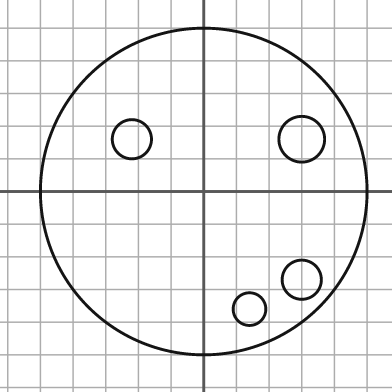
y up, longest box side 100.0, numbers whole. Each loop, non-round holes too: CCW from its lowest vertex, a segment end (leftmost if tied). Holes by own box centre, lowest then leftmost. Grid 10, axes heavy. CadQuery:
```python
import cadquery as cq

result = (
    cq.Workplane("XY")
    .moveTo(0.0, 0.0)
    .circle(50.0)
    .moveTo(14.0, -36.0)
    .circle(5.0)
    .moveTo(30.0, -27.0)
    .circle(6.0)
    .moveTo(-22.0, 16.0)
    .circle(6.0)
    .moveTo(30.0, 16.0)
    .circle(7.0)
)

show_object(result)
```